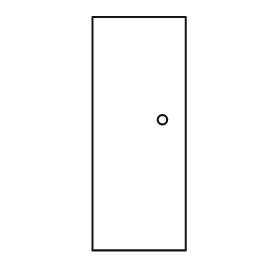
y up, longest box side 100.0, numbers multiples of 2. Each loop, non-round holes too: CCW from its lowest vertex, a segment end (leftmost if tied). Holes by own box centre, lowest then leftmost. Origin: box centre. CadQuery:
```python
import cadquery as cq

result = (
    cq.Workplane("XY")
    .moveTo(-20.0, -50.0)
    .lineTo(20.0, -50.0)
    .lineTo(20.0, 50.0)
    .lineTo(-20.0, 50.0)
    .close()
    .moveTo(10.0, 6.0)
    .circle(2.0)
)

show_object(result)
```